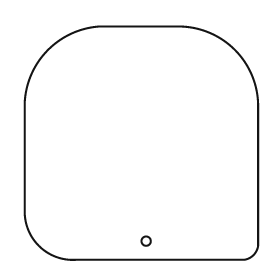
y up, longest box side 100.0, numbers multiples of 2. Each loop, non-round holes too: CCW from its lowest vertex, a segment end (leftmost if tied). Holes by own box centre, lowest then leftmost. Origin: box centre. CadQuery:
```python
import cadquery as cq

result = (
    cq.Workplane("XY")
    .moveTo(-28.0, -50.0)
    .lineTo(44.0, -50.0)
    .threePointArc((48.0, -48.0), (50.0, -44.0))
    .lineTo(50.0, 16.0)
    .threePointArc((40.0, 40.0), (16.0, 50.0))
    .lineTo(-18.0, 50.0)
    .threePointArc((-40.0, 40.0), (-50.0, 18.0))
    .lineTo(-50.0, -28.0)
    .threePointArc((-44.0, -44.0), (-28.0, -50.0))
    .close()
    .moveTo(2.0, -42.0)
    .circle(2.0)
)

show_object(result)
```